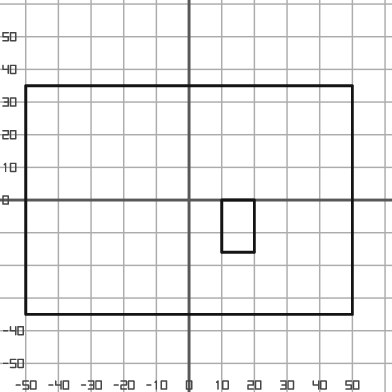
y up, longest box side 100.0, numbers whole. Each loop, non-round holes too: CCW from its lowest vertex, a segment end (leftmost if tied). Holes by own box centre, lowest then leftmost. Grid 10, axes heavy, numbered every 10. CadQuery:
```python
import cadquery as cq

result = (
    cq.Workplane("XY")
    .moveTo(-50.0, -35.0)
    .lineTo(50.0, -35.0)
    .lineTo(50.0, 35.0)
    .lineTo(-50.0, 35.0)
    .close()
    .moveTo(10.0, -16.0)
    .lineTo(20.0, -16.0)
    .lineTo(20.0, 0.0)
    .lineTo(10.0, 0.0)
    .close()
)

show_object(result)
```